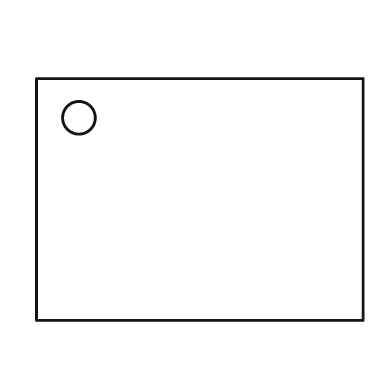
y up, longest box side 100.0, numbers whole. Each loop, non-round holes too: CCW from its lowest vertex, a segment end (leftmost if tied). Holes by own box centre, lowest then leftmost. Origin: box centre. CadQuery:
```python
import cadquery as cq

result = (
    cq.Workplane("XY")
    .moveTo(-50.0, -37.0)
    .lineTo(50.0, -37.0)
    .lineTo(50.0, 37.0)
    .lineTo(-50.0, 37.0)
    .close()
    .moveTo(-37.0, 25.0)
    .circle(5.0)
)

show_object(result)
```